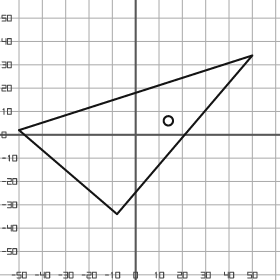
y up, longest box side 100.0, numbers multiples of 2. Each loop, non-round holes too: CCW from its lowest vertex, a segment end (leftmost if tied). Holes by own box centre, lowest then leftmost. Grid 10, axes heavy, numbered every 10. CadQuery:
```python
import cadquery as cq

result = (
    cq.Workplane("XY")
    .moveTo(-8.0, -34.0)
    .lineTo(50.0, 34.0)
    .lineTo(-50.0, 2.0)
    .close()
    .moveTo(14.0, 6.0)
    .circle(2.0)
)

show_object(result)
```